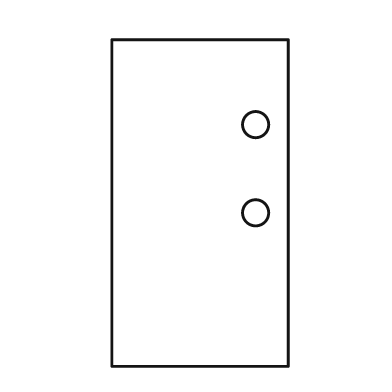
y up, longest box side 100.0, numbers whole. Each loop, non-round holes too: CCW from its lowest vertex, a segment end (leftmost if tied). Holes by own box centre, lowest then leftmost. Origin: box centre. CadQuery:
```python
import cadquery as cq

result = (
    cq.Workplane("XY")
    .moveTo(-27.0, -50.0)
    .lineTo(27.0, -50.0)
    .lineTo(27.0, 50.0)
    .lineTo(-27.0, 50.0)
    .close()
    .moveTo(17.0, -3.0)
    .circle(4.0)
    .moveTo(17.0, 24.0)
    .circle(4.0)
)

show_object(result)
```